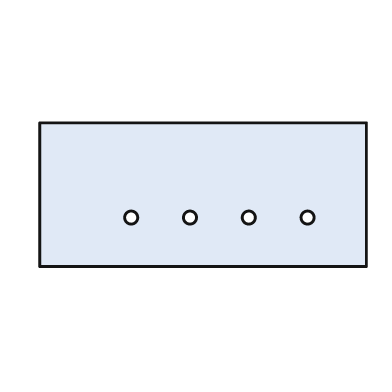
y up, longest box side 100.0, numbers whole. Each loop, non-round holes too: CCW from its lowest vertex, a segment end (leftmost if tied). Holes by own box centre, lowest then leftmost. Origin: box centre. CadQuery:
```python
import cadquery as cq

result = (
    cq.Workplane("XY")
    .moveTo(-50.0, -22.0)
    .lineTo(50.0, -22.0)
    .lineTo(50.0, 22.0)
    .lineTo(-50.0, 22.0)
    .close()
    .moveTo(-22.0, -7.0)
    .circle(2.0)
    .moveTo(-4.0, -7.0)
    .circle(2.0)
    .moveTo(14.0, -7.0)
    .circle(2.0)
    .moveTo(32.0, -7.0)
    .circle(2.0)
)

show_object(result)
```